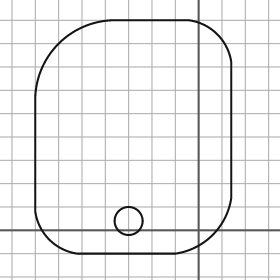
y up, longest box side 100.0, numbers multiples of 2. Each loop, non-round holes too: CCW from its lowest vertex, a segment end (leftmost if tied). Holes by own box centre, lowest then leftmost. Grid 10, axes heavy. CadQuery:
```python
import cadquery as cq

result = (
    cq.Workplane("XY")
    .moveTo(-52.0, -10.0)
    .lineTo(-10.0, -10.0)
    .threePointArc((6.0, -2.0), (14.0, 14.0))
    .lineTo(14.0, 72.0)
    .threePointArc((8.0, 84.0), (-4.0, 90.0))
    .lineTo(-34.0, 90.0)
    .threePointArc((-60.0, 80.0), (-70.0, 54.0))
    .lineTo(-70.0, 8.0)
    .threePointArc((-64.0, -4.0), (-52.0, -10.0))
    .close()
    .moveTo(-30.0, 4.0)
    .circle(6.0)
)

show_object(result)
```